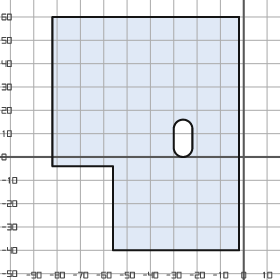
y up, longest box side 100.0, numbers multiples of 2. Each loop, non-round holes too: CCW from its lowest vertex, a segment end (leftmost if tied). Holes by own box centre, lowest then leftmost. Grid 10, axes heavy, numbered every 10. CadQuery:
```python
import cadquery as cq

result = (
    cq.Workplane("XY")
    .moveTo(-56.0, -40.0)
    .lineTo(-2.0, -40.0)
    .lineTo(-2.0, 60.0)
    .lineTo(-82.0, 60.0)
    .lineTo(-82.0, -4.0)
    .lineTo(-56.0, -4.0)
    .close()
    .moveTo(-30.0, 4.0)
    .threePointArc((-26.0, 0.0), (-22.0, 4.0))
    .lineTo(-22.0, 12.0)
    .threePointArc((-26.0, 16.0), (-30.0, 12.0))
    .close()
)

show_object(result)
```